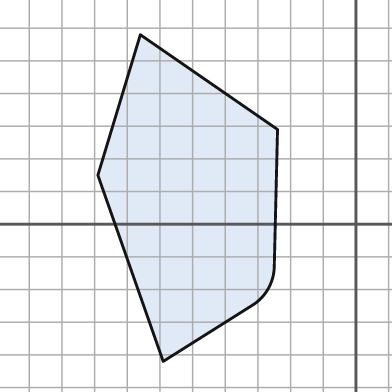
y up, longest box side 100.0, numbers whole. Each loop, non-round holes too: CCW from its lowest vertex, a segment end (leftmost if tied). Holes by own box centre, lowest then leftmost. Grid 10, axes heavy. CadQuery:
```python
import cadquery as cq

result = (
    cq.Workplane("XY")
    .moveTo(-59.0, -42.0)
    .lineTo(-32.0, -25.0)
    .threePointArc((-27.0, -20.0), (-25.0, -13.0))
    .lineTo(-24.0, 29.0)
    .lineTo(-66.0, 58.0)
    .lineTo(-79.0, 15.0)
    .close()
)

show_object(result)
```